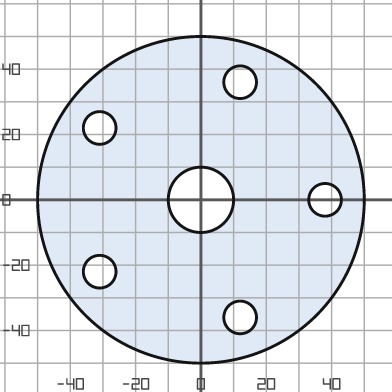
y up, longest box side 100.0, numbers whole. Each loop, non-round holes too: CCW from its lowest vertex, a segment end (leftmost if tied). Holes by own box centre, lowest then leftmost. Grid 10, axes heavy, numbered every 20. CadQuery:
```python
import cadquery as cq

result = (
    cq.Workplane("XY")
    .moveTo(0.0, 0.0)
    .circle(50.0)
    .moveTo(12.0, -36.0)
    .circle(5.0)
    .moveTo(-31.0, -22.0)
    .circle(5.0)
    .moveTo(0.0, 0.0)
    .circle(10.0)
    .moveTo(38.0, 0.0)
    .circle(5.0)
    .moveTo(-31.0, 22.0)
    .circle(5.0)
    .moveTo(12.0, 36.0)
    .circle(5.0)
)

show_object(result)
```